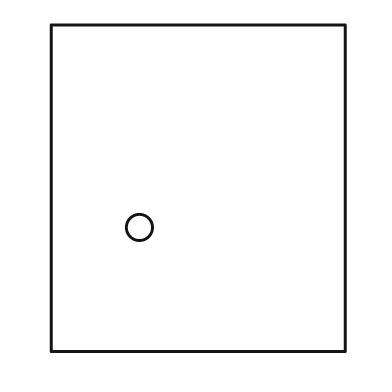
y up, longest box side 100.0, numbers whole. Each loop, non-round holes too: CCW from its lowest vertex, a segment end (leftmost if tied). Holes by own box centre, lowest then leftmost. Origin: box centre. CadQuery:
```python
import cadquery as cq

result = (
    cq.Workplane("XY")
    .moveTo(-45.0, -50.0)
    .lineTo(45.0, -50.0)
    .lineTo(45.0, 50.0)
    .lineTo(-45.0, 50.0)
    .close()
    .moveTo(-18.0, -12.0)
    .circle(4.0)
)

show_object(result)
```